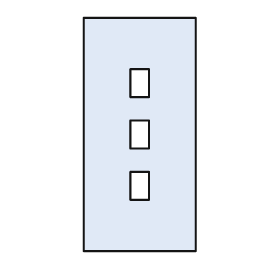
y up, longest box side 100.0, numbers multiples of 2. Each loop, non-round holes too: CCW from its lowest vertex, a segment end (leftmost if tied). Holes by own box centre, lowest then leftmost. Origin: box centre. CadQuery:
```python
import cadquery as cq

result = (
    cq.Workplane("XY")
    .moveTo(-24.0, -50.0)
    .lineTo(24.0, -50.0)
    .lineTo(24.0, 50.0)
    .lineTo(-24.0, 50.0)
    .close()
    .moveTo(-4.0, -28.0)
    .lineTo(4.0, -28.0)
    .lineTo(4.0, -16.0)
    .lineTo(-4.0, -16.0)
    .close()
    .moveTo(-4.0, -6.0)
    .lineTo(4.0, -6.0)
    .lineTo(4.0, 6.0)
    .lineTo(-4.0, 6.0)
    .close()
    .moveTo(-4.0, 16.0)
    .lineTo(4.0, 16.0)
    .lineTo(4.0, 28.0)
    .lineTo(-4.0, 28.0)
    .close()
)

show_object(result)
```